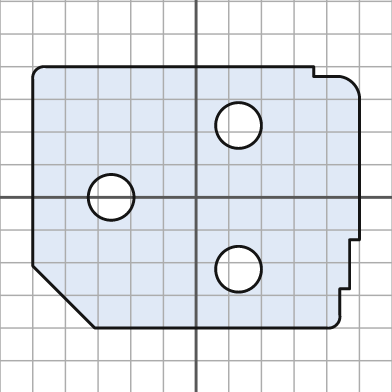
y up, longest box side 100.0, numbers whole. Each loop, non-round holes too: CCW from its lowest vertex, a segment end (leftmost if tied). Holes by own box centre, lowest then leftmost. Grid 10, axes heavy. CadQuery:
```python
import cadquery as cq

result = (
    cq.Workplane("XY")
    .moveTo(-31.0, -40.0)
    .lineTo(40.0, -40.0)
    .threePointArc((43.0, -39.0), (44.0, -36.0))
    .lineTo(44.0, -28.0)
    .lineTo(47.0, -28.0)
    .lineTo(47.0, -13.0)
    .lineTo(50.0, -13.0)
    .lineTo(50.0, 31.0)
    .threePointArc((48.0, 35.0), (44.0, 37.0))
    .lineTo(36.0, 37.0)
    .lineTo(36.0, 40.0)
    .lineTo(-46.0, 40.0)
    .threePointArc((-49.0, 39.0), (-50.0, 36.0))
    .lineTo(-50.0, -21.0)
    .close()
    .moveTo(13.0, -22.0)
    .circle(7.0)
    .moveTo(-26.0, 0.0)
    .circle(7.0)
    .moveTo(13.0, 22.0)
    .circle(7.0)
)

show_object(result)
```